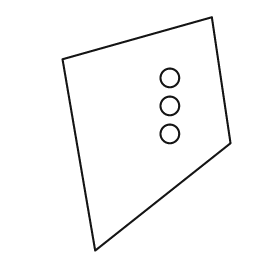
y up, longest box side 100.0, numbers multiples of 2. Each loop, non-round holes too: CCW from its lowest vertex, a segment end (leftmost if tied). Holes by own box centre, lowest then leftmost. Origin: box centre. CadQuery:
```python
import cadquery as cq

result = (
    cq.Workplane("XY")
    .moveTo(-22.0, -50.0)
    .lineTo(36.0, -4.0)
    .lineTo(28.0, 50.0)
    .lineTo(-36.0, 32.0)
    .close()
    .moveTo(10.0, 0.0)
    .circle(4.0)
    .moveTo(10.0, 12.0)
    .circle(4.0)
    .moveTo(10.0, 24.0)
    .circle(4.0)
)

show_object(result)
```